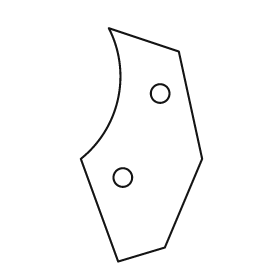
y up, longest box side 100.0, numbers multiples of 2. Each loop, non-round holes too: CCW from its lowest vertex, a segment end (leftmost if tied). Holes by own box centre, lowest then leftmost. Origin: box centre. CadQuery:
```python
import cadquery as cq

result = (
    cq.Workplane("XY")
    .moveTo(-10.0, -50.0)
    .lineTo(10.0, -44.0)
    .lineTo(26.0, -6.0)
    .lineTo(16.0, 40.0)
    .lineTo(-14.0, 50.0)
    .threePointArc((-10.0, 20.0), (-26.0, -6.0))
    .close()
    .moveTo(-8.0, -14.0)
    .circle(4.0)
    .moveTo(8.0, 22.0)
    .circle(4.0)
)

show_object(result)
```